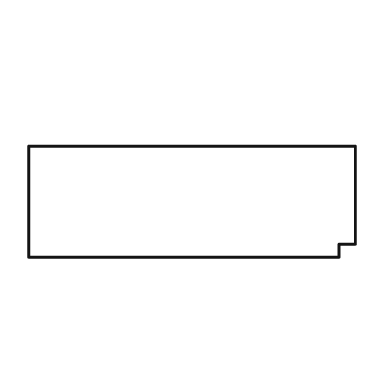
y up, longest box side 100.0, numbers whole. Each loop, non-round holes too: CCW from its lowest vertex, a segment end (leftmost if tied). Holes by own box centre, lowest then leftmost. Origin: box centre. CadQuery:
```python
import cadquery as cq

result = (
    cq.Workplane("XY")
    .moveTo(-50.0, -17.0)
    .lineTo(45.0, -17.0)
    .lineTo(45.0, -13.0)
    .lineTo(50.0, -13.0)
    .lineTo(50.0, 17.0)
    .lineTo(-50.0, 17.0)
    .close()
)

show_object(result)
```